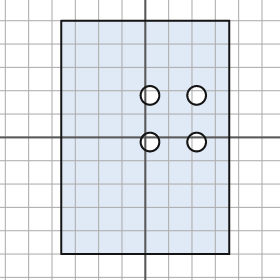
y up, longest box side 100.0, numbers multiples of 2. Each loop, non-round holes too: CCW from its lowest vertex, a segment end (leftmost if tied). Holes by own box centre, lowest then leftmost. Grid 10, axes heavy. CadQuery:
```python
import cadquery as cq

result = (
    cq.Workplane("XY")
    .moveTo(-36.0, -50.0)
    .lineTo(36.0, -50.0)
    .lineTo(36.0, 50.0)
    .lineTo(-36.0, 50.0)
    .close()
    .moveTo(2.0, -2.0)
    .circle(4.0)
    .moveTo(22.0, -2.0)
    .circle(4.0)
    .moveTo(2.0, 18.0)
    .circle(4.0)
    .moveTo(22.0, 18.0)
    .circle(4.0)
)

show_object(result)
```